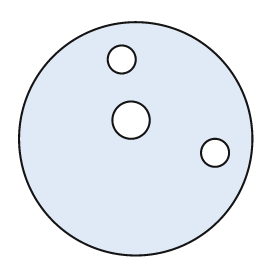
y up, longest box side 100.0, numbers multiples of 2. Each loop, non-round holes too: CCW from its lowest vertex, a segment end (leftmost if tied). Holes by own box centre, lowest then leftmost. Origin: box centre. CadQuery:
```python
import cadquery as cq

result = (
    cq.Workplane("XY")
    .moveTo(0.0, 0.0)
    .circle(50.0)
    .moveTo(34.0, -6.0)
    .circle(6.0)
    .moveTo(-2.0, 8.0)
    .circle(8.0)
    .moveTo(-6.0, 34.0)
    .circle(6.0)
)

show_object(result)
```